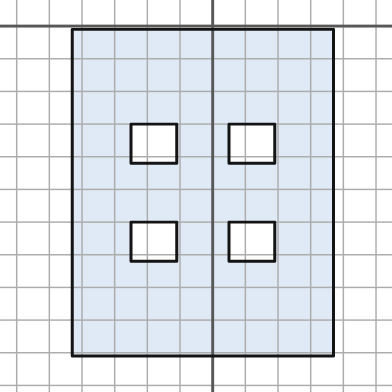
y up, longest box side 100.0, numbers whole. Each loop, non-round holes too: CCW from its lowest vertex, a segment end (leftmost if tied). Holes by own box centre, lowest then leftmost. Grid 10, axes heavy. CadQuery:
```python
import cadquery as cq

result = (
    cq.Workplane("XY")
    .moveTo(-43.0, -101.0)
    .lineTo(37.0, -101.0)
    .lineTo(37.0, -1.0)
    .lineTo(-43.0, -1.0)
    .close()
    .moveTo(-25.0, -72.0)
    .lineTo(-11.0, -72.0)
    .lineTo(-11.0, -60.0)
    .lineTo(-25.0, -60.0)
    .close()
    .moveTo(5.0, -72.0)
    .lineTo(19.0, -72.0)
    .lineTo(19.0, -60.0)
    .lineTo(5.0, -60.0)
    .close()
    .moveTo(-25.0, -42.0)
    .lineTo(-11.0, -42.0)
    .lineTo(-11.0, -30.0)
    .lineTo(-25.0, -30.0)
    .close()
    .moveTo(5.0, -42.0)
    .lineTo(19.0, -42.0)
    .lineTo(19.0, -30.0)
    .lineTo(5.0, -30.0)
    .close()
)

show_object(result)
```